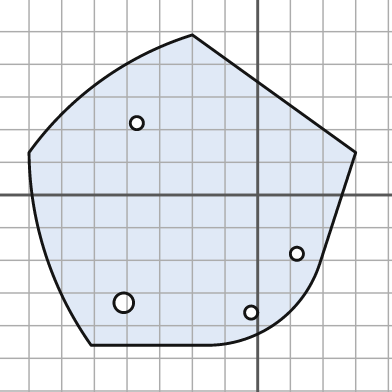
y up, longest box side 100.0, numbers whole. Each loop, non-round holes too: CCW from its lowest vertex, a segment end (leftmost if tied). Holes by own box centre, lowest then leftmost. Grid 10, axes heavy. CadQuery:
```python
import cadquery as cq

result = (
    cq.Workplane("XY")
    .moveTo(-51.0, -46.0)
    .lineTo(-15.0, -46.0)
    .threePointArc((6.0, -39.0), (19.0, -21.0))
    .lineTo(30.0, 13.0)
    .lineTo(-20.0, 49.0)
    .threePointArc((-48.0, 35.0), (-70.0, 13.0))
    .threePointArc((-65.0, -18.0), (-51.0, -46.0))
    .close()
    .moveTo(-2.0, -36.0)
    .circle(2.0)
    .moveTo(-41.0, -33.0)
    .circle(3.0)
    .moveTo(12.0, -18.0)
    .circle(2.0)
    .moveTo(-37.0, 22.0)
    .circle(2.0)
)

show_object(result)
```